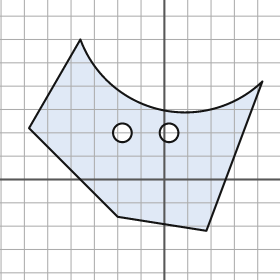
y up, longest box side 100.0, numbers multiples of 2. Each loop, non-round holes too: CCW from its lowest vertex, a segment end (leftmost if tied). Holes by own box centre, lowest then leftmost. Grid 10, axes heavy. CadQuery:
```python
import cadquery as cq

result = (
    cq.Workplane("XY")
    .moveTo(18.0, -22.0)
    .lineTo(42.0, 42.0)
    .threePointArc((-2.0, 30.0), (-36.0, 60.0))
    .lineTo(-58.0, 22.0)
    .lineTo(-20.0, -16.0)
    .close()
    .moveTo(-18.0, 20.0)
    .circle(4.0)
    .moveTo(2.0, 20.0)
    .circle(4.0)
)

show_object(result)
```